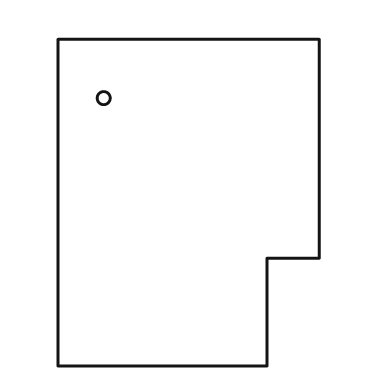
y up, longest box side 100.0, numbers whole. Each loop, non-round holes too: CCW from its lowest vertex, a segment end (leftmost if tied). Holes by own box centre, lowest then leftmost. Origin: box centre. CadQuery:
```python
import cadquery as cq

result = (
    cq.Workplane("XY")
    .moveTo(-40.0, -50.0)
    .lineTo(24.0, -50.0)
    .lineTo(24.0, -17.0)
    .lineTo(40.0, -17.0)
    .lineTo(40.0, 50.0)
    .lineTo(-40.0, 50.0)
    .close()
    .moveTo(-26.0, 32.0)
    .circle(2.0)
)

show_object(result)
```